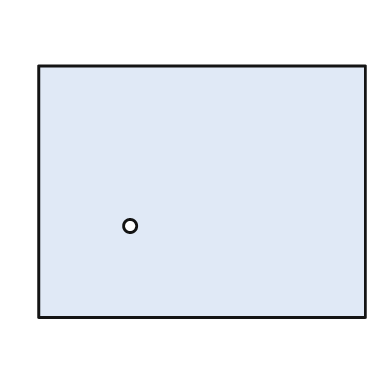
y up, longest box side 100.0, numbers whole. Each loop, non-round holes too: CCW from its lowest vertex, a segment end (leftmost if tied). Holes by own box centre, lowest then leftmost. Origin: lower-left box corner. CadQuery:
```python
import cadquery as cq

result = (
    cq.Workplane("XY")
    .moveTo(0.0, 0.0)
    .lineTo(100.0, 0.0)
    .lineTo(100.0, 77.0)
    .lineTo(0.0, 77.0)
    .close()
    .moveTo(28.0, 28.0)
    .circle(2.0)
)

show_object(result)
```